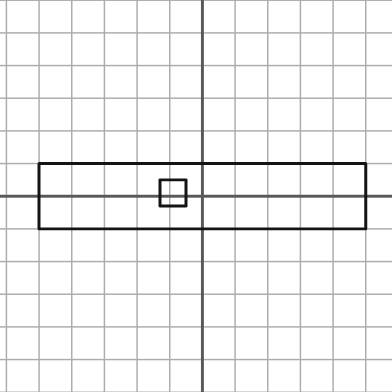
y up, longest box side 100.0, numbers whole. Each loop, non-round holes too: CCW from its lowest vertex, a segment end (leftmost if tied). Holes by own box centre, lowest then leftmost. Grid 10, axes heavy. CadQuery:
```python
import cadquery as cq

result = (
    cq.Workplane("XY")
    .moveTo(-50.0, -10.0)
    .lineTo(50.0, -10.0)
    .lineTo(50.0, 10.0)
    .lineTo(-50.0, 10.0)
    .close()
    .moveTo(-13.0, -3.0)
    .lineTo(-5.0, -3.0)
    .lineTo(-5.0, 5.0)
    .lineTo(-13.0, 5.0)
    .close()
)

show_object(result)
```